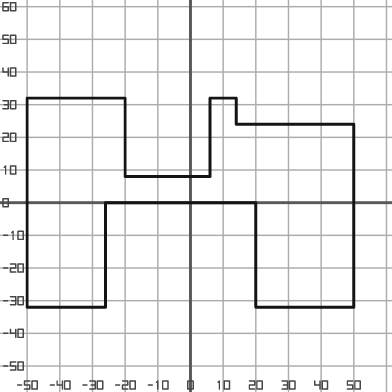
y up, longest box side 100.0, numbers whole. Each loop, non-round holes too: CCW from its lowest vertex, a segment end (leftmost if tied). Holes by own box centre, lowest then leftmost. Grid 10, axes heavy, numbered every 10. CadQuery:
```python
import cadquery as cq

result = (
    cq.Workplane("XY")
    .moveTo(-50.0, -32.0)
    .lineTo(-26.0, -32.0)
    .lineTo(-26.0, 0.0)
    .lineTo(20.0, 0.0)
    .lineTo(20.0, -32.0)
    .lineTo(50.0, -32.0)
    .lineTo(50.0, 24.0)
    .lineTo(14.0, 24.0)
    .lineTo(14.0, 32.0)
    .lineTo(6.0, 32.0)
    .lineTo(6.0, 8.0)
    .lineTo(-20.0, 8.0)
    .lineTo(-20.0, 32.0)
    .lineTo(-50.0, 32.0)
    .close()
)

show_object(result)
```